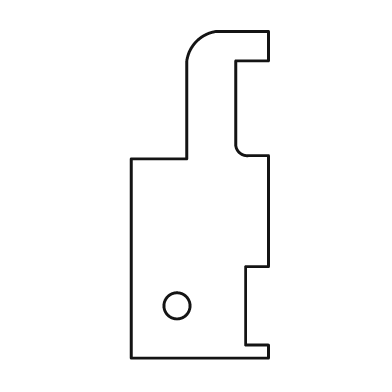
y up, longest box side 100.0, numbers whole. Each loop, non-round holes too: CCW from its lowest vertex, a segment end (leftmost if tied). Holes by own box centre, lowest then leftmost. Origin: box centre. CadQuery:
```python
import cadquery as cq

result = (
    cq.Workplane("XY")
    .moveTo(-21.0, -50.0)
    .lineTo(21.0, -50.0)
    .lineTo(21.0, -46.0)
    .lineTo(14.0, -46.0)
    .lineTo(14.0, -22.0)
    .lineTo(21.0, -22.0)
    .lineTo(21.0, 12.0)
    .lineTo(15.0, 12.0)
    .threePointArc((12.0, 13.0), (11.0, 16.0))
    .lineTo(11.0, 41.0)
    .lineTo(21.0, 41.0)
    .lineTo(21.0, 50.0)
    .lineTo(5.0, 50.0)
    .threePointArc((-1.0, 47.0), (-4.0, 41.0))
    .lineTo(-4.0, 11.0)
    .lineTo(-21.0, 11.0)
    .close()
    .moveTo(-7.0, -34.0)
    .circle(4.0)
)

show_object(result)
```